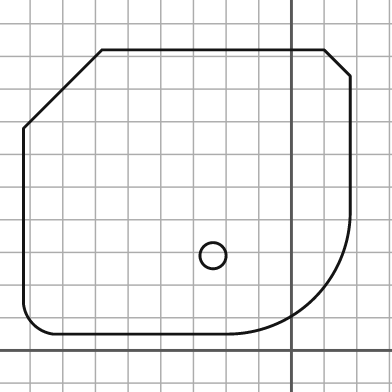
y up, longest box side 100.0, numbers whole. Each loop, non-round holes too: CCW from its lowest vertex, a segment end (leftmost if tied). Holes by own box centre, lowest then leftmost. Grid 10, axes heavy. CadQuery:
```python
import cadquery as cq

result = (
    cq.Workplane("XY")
    .moveTo(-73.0, 5.0)
    .lineTo(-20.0, 5.0)
    .threePointArc((7.0, 16.0), (18.0, 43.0))
    .lineTo(18.0, 84.0)
    .lineTo(10.0, 92.0)
    .lineTo(-58.0, 92.0)
    .lineTo(-82.0, 68.0)
    .lineTo(-82.0, 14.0)
    .threePointArc((-79.0, 8.0), (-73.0, 5.0))
    .close()
    .moveTo(-24.0, 29.0)
    .circle(4.0)
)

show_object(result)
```